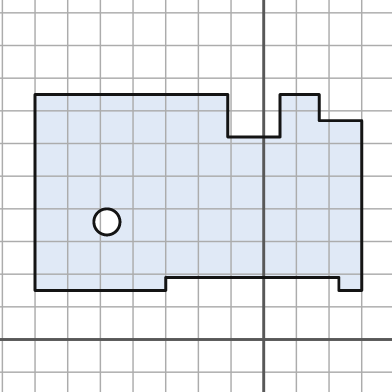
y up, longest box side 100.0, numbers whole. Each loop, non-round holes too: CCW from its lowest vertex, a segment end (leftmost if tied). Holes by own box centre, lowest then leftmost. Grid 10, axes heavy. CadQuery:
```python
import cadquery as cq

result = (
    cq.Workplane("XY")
    .moveTo(-70.0, 15.0)
    .lineTo(-30.0, 15.0)
    .lineTo(-30.0, 19.0)
    .lineTo(23.0, 19.0)
    .lineTo(23.0, 15.0)
    .lineTo(30.0, 15.0)
    .lineTo(30.0, 67.0)
    .lineTo(17.0, 67.0)
    .lineTo(17.0, 75.0)
    .lineTo(5.0, 75.0)
    .lineTo(5.0, 62.0)
    .lineTo(-11.0, 62.0)
    .lineTo(-11.0, 75.0)
    .lineTo(-70.0, 75.0)
    .close()
    .moveTo(-48.0, 36.0)
    .circle(4.0)
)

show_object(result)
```